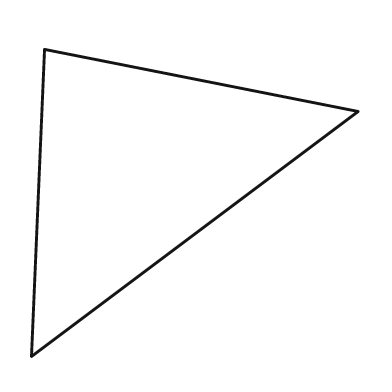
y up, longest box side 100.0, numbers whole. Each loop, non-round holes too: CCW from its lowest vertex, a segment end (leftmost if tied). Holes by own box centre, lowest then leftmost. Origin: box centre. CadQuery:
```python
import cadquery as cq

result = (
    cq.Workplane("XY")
    .moveTo(-50.0, -47.0)
    .lineTo(50.0, 28.0)
    .lineTo(-46.0, 47.0)
    .close()
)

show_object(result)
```